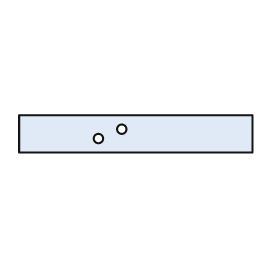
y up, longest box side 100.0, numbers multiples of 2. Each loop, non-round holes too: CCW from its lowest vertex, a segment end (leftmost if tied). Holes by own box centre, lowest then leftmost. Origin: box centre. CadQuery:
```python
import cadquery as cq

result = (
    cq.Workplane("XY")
    .moveTo(-50.0, -8.0)
    .lineTo(50.0, -8.0)
    .lineTo(50.0, 8.0)
    .lineTo(-50.0, 8.0)
    .close()
    .moveTo(-16.0, -2.0)
    .circle(2.0)
    .moveTo(-6.0, 2.0)
    .circle(2.0)
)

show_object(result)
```